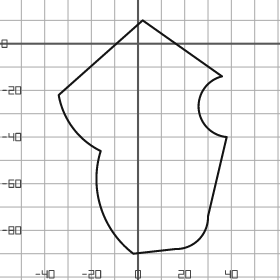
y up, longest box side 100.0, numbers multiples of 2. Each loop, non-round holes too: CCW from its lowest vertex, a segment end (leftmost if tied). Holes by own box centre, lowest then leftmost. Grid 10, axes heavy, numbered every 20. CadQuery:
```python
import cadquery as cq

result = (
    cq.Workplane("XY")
    .moveTo(-2.0, -90.0)
    .lineTo(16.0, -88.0)
    .threePointArc((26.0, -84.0), (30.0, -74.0))
    .lineTo(38.0, -40.0)
    .threePointArc((26.0, -28.0), (36.0, -14.0))
    .lineTo(2.0, 10.0)
    .lineTo(-34.0, -22.0)
    .threePointArc((-28.0, -36.0), (-16.0, -46.0))
    .threePointArc((-16.0, -70.0), (-2.0, -90.0))
    .close()
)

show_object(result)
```